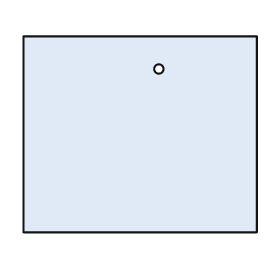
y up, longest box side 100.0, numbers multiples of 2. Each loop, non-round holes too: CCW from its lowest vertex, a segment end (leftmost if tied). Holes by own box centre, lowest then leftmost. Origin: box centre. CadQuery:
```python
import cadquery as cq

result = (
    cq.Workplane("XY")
    .moveTo(-50.0, -42.0)
    .lineTo(50.0, -42.0)
    .lineTo(50.0, 42.0)
    .lineTo(-50.0, 42.0)
    .close()
    .moveTo(8.0, 28.0)
    .circle(2.0)
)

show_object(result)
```